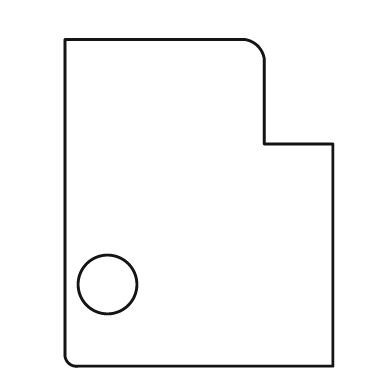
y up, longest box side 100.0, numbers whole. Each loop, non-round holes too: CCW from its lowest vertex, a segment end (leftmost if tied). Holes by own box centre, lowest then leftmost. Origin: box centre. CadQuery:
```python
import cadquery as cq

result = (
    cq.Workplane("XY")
    .moveTo(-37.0, -50.0)
    .lineTo(41.0, -50.0)
    .lineTo(41.0, 18.0)
    .lineTo(20.0, 18.0)
    .lineTo(20.0, 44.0)
    .threePointArc((18.0, 48.0), (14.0, 50.0))
    .lineTo(-41.0, 50.0)
    .lineTo(-41.0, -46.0)
    .threePointArc((-40.0, -49.0), (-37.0, -50.0))
    .close()
    .moveTo(-28.0, -25.0)
    .circle(9.0)
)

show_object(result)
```